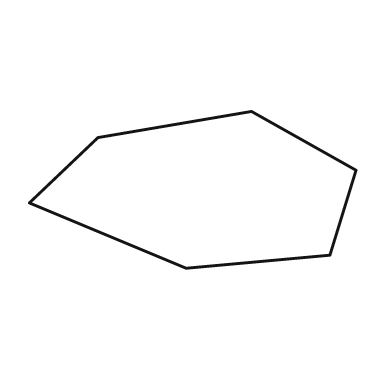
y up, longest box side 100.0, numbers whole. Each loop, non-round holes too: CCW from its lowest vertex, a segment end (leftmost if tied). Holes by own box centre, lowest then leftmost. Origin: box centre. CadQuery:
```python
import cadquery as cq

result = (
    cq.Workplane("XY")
    .moveTo(-2.0, -24.0)
    .lineTo(42.0, -20.0)
    .lineTo(50.0, 6.0)
    .lineTo(18.0, 24.0)
    .lineTo(-29.0, 16.0)
    .lineTo(-50.0, -4.0)
    .close()
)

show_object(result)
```